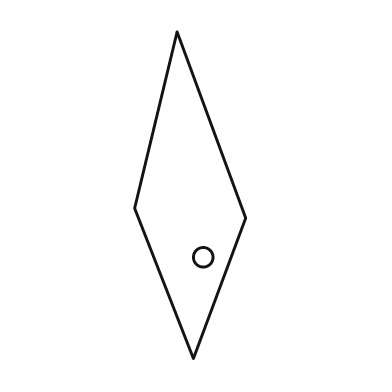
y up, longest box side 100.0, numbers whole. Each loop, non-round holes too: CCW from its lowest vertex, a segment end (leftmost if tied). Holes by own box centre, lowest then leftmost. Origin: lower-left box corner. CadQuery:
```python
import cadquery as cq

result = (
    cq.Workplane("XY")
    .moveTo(18.0, 0.0)
    .lineTo(34.0, 43.0)
    .lineTo(13.0, 100.0)
    .lineTo(0.0, 46.0)
    .close()
    .moveTo(21.0, 31.0)
    .circle(3.0)
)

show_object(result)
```